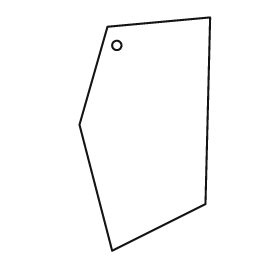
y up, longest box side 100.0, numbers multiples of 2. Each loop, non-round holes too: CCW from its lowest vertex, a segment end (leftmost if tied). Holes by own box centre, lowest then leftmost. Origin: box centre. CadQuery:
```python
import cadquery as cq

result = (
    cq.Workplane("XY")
    .moveTo(-14.0, -50.0)
    .lineTo(26.0, -30.0)
    .lineTo(28.0, 50.0)
    .lineTo(-16.0, 46.0)
    .lineTo(-28.0, 4.0)
    .close()
    .moveTo(-12.0, 38.0)
    .circle(2.0)
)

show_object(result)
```